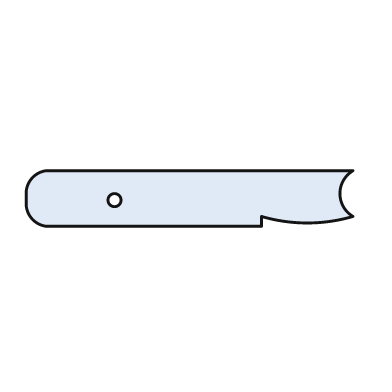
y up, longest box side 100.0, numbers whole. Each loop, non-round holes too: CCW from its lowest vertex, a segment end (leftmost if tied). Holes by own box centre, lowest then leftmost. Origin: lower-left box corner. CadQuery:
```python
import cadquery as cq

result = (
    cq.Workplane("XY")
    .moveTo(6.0, 0.0)
    .lineTo(72.0, 0.0)
    .lineTo(72.0, 3.0)
    .threePointArc((86.0, 1.0), (100.0, 3.0))
    .threePointArc((96.0, 10.0), (100.0, 17.0))
    .lineTo(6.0, 17.0)
    .threePointArc((2.0, 15.0), (0.0, 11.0))
    .lineTo(0.0, 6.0)
    .threePointArc((2.0, 2.0), (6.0, 0.0))
    .close()
    .moveTo(27.0, 8.0)
    .circle(2.0)
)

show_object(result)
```